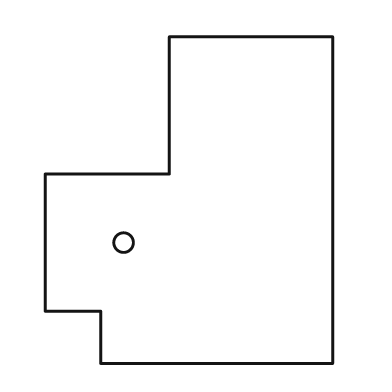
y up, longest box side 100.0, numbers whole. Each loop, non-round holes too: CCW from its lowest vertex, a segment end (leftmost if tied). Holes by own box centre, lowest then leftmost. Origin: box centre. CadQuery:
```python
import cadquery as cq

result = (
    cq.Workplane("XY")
    .moveTo(-27.0, -50.0)
    .lineTo(44.0, -50.0)
    .lineTo(44.0, 50.0)
    .lineTo(-6.0, 50.0)
    .lineTo(-6.0, 8.0)
    .lineTo(-44.0, 8.0)
    .lineTo(-44.0, -34.0)
    .lineTo(-27.0, -34.0)
    .close()
    .moveTo(-20.0, -13.0)
    .circle(3.0)
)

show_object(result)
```